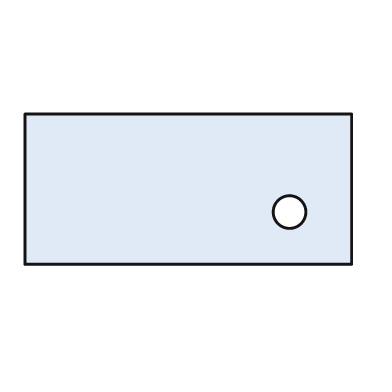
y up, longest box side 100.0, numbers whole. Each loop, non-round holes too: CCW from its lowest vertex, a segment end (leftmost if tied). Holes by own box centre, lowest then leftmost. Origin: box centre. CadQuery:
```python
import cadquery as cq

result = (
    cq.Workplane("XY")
    .moveTo(-50.0, -23.0)
    .lineTo(50.0, -23.0)
    .lineTo(50.0, 23.0)
    .lineTo(-50.0, 23.0)
    .close()
    .moveTo(31.0, -7.0)
    .circle(5.0)
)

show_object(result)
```